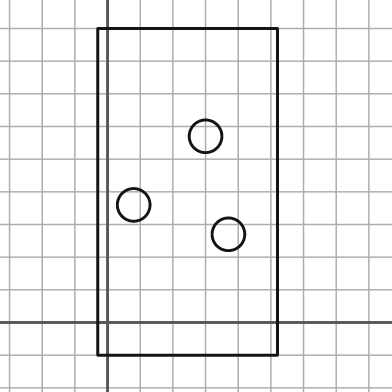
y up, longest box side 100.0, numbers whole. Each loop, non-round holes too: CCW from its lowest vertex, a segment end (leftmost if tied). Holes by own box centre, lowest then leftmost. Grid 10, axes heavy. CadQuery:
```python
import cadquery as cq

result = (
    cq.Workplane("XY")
    .moveTo(-3.0, -10.0)
    .lineTo(52.0, -10.0)
    .lineTo(52.0, 90.0)
    .lineTo(-3.0, 90.0)
    .close()
    .moveTo(37.0, 27.0)
    .circle(5.0)
    .moveTo(8.0, 36.0)
    .circle(5.0)
    .moveTo(30.0, 57.0)
    .circle(5.0)
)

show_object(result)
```